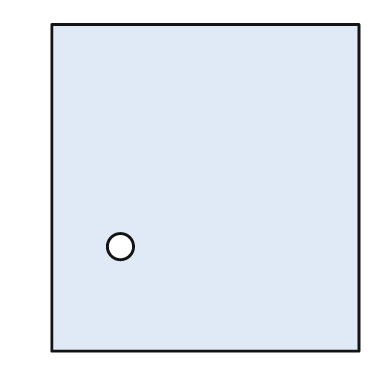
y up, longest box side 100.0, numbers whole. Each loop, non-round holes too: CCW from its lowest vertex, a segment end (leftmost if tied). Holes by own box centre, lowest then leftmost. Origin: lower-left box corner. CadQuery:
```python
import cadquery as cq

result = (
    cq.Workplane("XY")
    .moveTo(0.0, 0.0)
    .lineTo(94.0, 0.0)
    .lineTo(94.0, 100.0)
    .lineTo(0.0, 100.0)
    .close()
    .moveTo(21.0, 32.0)
    .circle(4.0)
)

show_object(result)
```